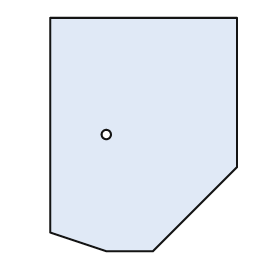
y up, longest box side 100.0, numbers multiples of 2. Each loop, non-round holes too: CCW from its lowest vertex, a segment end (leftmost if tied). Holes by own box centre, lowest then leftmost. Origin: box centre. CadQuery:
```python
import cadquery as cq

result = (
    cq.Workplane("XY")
    .moveTo(-16.0, -50.0)
    .lineTo(4.0, -50.0)
    .lineTo(40.0, -14.0)
    .lineTo(40.0, 50.0)
    .lineTo(-40.0, 50.0)
    .lineTo(-40.0, -42.0)
    .close()
    .moveTo(-16.0, 0.0)
    .circle(2.0)
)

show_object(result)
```